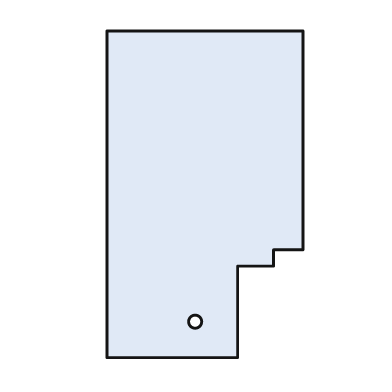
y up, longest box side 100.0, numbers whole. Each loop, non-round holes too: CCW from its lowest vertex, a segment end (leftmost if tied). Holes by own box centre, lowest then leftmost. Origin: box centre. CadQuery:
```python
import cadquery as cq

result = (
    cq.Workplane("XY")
    .moveTo(-30.0, -50.0)
    .lineTo(10.0, -50.0)
    .lineTo(10.0, -22.0)
    .lineTo(21.0, -22.0)
    .lineTo(21.0, -17.0)
    .lineTo(30.0, -17.0)
    .lineTo(30.0, 50.0)
    .lineTo(-30.0, 50.0)
    .close()
    .moveTo(-3.0, -39.0)
    .circle(2.0)
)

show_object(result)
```